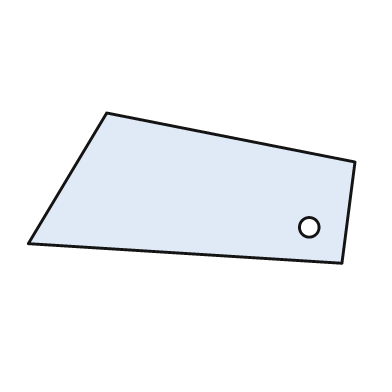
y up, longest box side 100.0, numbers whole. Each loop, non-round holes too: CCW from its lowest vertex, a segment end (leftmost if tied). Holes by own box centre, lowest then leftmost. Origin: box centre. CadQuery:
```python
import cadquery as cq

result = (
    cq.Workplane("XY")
    .moveTo(46.0, -23.0)
    .lineTo(50.0, 8.0)
    .lineTo(-26.0, 23.0)
    .lineTo(-50.0, -17.0)
    .close()
    .moveTo(36.0, -12.0)
    .circle(3.0)
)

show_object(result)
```